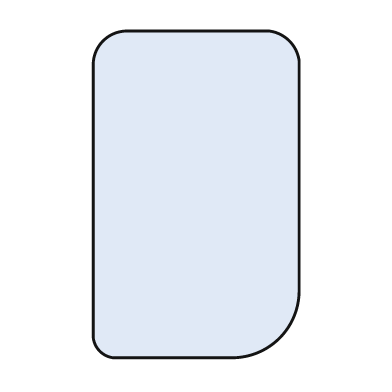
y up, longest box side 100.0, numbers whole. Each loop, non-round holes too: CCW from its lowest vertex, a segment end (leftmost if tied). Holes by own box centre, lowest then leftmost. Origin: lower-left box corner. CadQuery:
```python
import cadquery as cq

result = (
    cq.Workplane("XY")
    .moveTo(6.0, 0.0)
    .lineTo(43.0, 0.0)
    .threePointArc((57.0, 6.0), (63.0, 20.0))
    .lineTo(63.0, 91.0)
    .threePointArc((60.0, 97.0), (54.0, 100.0))
    .lineTo(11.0, 100.0)
    .threePointArc((3.0, 97.0), (0.0, 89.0))
    .lineTo(0.0, 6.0)
    .threePointArc((2.0, 2.0), (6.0, 0.0))
    .close()
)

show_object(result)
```